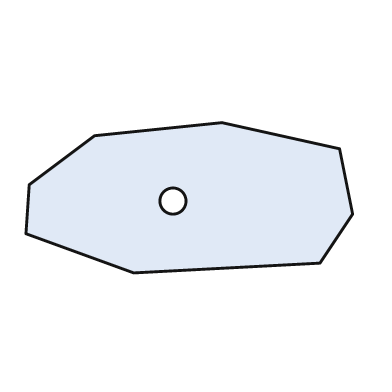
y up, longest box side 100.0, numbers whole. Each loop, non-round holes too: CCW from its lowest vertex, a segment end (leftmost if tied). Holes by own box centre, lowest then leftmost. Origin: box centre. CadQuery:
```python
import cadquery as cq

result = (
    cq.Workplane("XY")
    .moveTo(-17.0, -23.0)
    .lineTo(40.0, -20.0)
    .lineTo(50.0, -5.0)
    .lineTo(46.0, 15.0)
    .lineTo(10.0, 23.0)
    .lineTo(-29.0, 19.0)
    .lineTo(-49.0, 4.0)
    .lineTo(-50.0, -11.0)
    .close()
    .moveTo(-5.0, -1.0)
    .circle(4.0)
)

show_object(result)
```